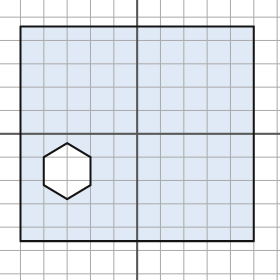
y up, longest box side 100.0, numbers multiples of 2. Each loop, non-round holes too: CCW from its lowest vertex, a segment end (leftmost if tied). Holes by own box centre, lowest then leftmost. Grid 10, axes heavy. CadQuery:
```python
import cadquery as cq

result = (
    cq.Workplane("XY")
    .moveTo(-50.0, -46.0)
    .lineTo(50.0, -46.0)
    .lineTo(50.0, 46.0)
    .lineTo(-50.0, 46.0)
    .close()
    .moveTo(-30.0, -28.0)
    .lineTo(-20.0, -22.0)
    .lineTo(-20.0, -10.0)
    .lineTo(-30.0, -4.0)
    .lineTo(-40.0, -10.0)
    .lineTo(-40.0, -22.0)
    .close()
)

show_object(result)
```